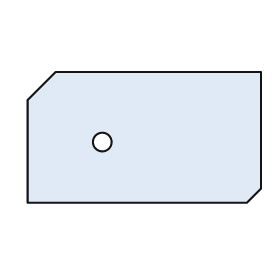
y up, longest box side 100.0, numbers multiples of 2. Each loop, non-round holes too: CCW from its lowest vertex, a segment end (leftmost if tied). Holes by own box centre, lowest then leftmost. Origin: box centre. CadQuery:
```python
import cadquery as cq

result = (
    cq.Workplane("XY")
    .moveTo(-50.0, -28.0)
    .lineTo(44.0, -28.0)
    .lineTo(50.0, -22.0)
    .lineTo(50.0, 28.0)
    .lineTo(-38.0, 28.0)
    .lineTo(-50.0, 16.0)
    .close()
    .moveTo(-18.0, -2.0)
    .circle(4.0)
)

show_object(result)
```